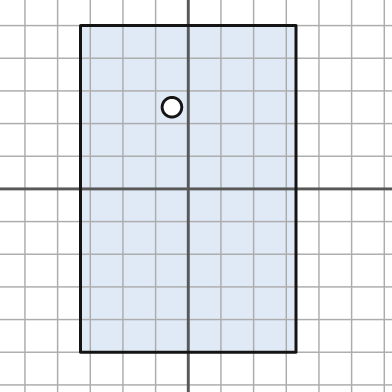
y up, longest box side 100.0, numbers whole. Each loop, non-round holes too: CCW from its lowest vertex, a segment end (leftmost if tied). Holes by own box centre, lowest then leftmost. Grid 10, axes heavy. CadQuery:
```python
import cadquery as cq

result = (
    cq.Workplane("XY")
    .moveTo(-33.0, -50.0)
    .lineTo(33.0, -50.0)
    .lineTo(33.0, 50.0)
    .lineTo(-33.0, 50.0)
    .close()
    .moveTo(-5.0, 25.0)
    .circle(3.0)
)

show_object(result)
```